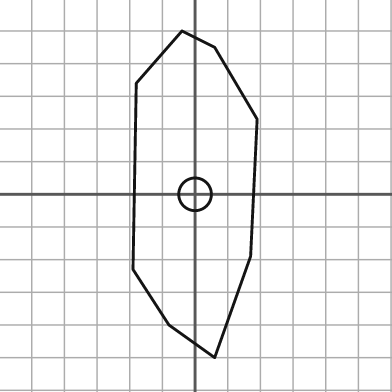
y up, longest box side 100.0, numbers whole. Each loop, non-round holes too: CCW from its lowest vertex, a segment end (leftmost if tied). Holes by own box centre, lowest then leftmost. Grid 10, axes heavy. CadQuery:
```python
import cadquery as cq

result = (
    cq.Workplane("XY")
    .moveTo(6.0, -50.0)
    .lineTo(17.0, -19.0)
    .lineTo(19.0, 23.0)
    .lineTo(6.0, 45.0)
    .lineTo(-4.0, 50.0)
    .lineTo(-18.0, 34.0)
    .lineTo(-19.0, -23.0)
    .lineTo(-8.0, -40.0)
    .close()
    .moveTo(0.0, 0.0)
    .circle(5.0)
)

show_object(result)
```